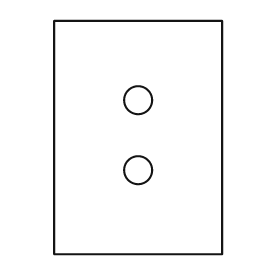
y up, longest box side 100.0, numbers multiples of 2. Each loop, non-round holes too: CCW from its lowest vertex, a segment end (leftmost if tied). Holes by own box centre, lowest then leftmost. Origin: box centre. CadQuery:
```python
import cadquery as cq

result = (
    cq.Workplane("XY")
    .moveTo(-36.0, -50.0)
    .lineTo(36.0, -50.0)
    .lineTo(36.0, 50.0)
    .lineTo(-36.0, 50.0)
    .close()
    .moveTo(0.0, -14.0)
    .circle(6.0)
    .moveTo(0.0, 16.0)
    .circle(6.0)
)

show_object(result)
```